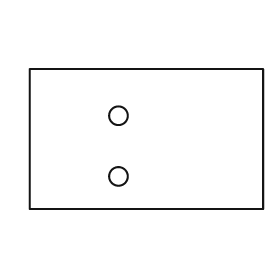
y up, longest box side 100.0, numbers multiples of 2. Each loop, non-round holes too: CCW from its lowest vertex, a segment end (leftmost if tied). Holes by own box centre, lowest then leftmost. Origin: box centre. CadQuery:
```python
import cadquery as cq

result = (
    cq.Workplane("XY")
    .moveTo(-50.0, -30.0)
    .lineTo(50.0, -30.0)
    .lineTo(50.0, 30.0)
    .lineTo(-50.0, 30.0)
    .close()
    .moveTo(-12.0, -16.0)
    .circle(4.0)
    .moveTo(-12.0, 10.0)
    .circle(4.0)
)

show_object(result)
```